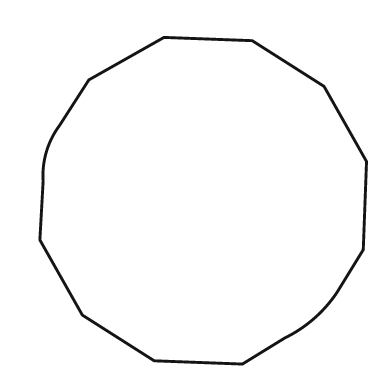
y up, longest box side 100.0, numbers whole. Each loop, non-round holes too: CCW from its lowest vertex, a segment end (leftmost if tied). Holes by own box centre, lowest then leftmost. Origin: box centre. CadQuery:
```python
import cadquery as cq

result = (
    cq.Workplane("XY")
    .moveTo(12.0, -50.0)
    .lineTo(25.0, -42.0)
    .threePointArc((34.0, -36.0), (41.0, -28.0))
    .lineTo(49.0, -15.0)
    .lineTo(50.0, 12.0)
    .lineTo(37.0, 35.0)
    .lineTo(15.0, 49.0)
    .lineTo(-12.0, 50.0)
    .lineTo(-35.0, 37.0)
    .lineTo(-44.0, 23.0)
    .threePointArc((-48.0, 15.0), (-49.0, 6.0))
    .lineTo(-50.0, -12.0)
    .lineTo(-37.0, -35.0)
    .lineTo(-15.0, -49.0)
    .close()
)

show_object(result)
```